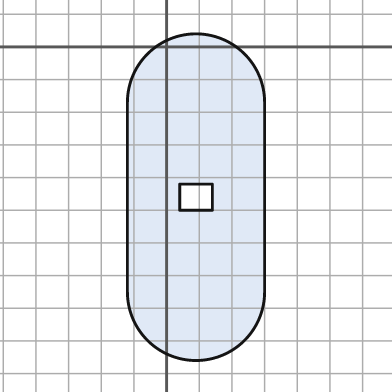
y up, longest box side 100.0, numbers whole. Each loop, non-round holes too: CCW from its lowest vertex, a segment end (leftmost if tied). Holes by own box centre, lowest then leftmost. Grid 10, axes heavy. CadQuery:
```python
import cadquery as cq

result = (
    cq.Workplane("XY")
    .moveTo(-12.0, -75.0)
    .threePointArc((9.0, -96.0), (30.0, -75.0))
    .lineTo(30.0, -17.0)
    .threePointArc((9.0, 4.0), (-12.0, -17.0))
    .close()
    .moveTo(4.0, -50.0)
    .lineTo(14.0, -50.0)
    .lineTo(14.0, -42.0)
    .lineTo(4.0, -42.0)
    .close()
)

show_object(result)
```